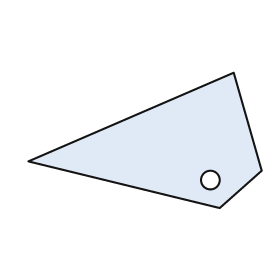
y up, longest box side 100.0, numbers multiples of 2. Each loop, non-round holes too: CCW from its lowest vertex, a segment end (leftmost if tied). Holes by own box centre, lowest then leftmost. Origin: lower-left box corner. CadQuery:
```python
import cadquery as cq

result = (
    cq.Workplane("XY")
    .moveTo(82.0, 0.0)
    .lineTo(100.0, 16.0)
    .lineTo(88.0, 58.0)
    .lineTo(0.0, 20.0)
    .close()
    .moveTo(78.0, 12.0)
    .circle(4.0)
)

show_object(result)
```